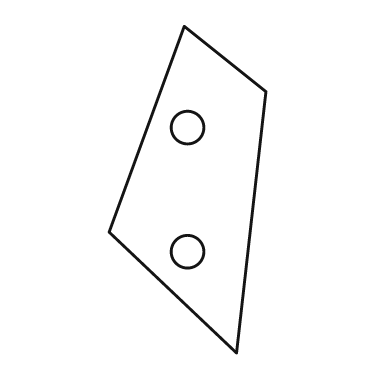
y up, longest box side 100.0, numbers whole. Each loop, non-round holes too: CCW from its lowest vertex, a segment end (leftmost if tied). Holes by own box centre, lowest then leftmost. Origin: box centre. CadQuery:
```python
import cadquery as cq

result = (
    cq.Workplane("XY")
    .moveTo(15.0, -50.0)
    .lineTo(24.0, 30.0)
    .lineTo(-1.0, 50.0)
    .lineTo(-24.0, -13.0)
    .close()
    .moveTo(0.0, -19.0)
    .circle(5.0)
    .moveTo(0.0, 19.0)
    .circle(5.0)
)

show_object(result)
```